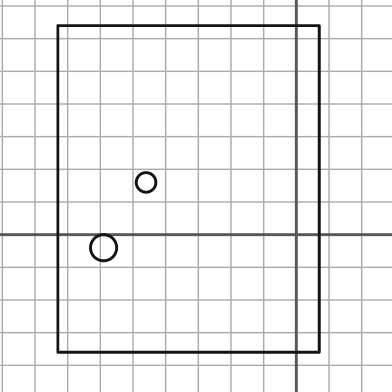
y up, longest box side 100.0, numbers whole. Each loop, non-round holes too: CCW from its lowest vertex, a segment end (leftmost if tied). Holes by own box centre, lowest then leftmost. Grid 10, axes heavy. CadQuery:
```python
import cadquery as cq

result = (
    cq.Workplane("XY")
    .moveTo(-73.0, -36.0)
    .lineTo(7.0, -36.0)
    .lineTo(7.0, 64.0)
    .lineTo(-73.0, 64.0)
    .close()
    .moveTo(-59.0, -4.0)
    .circle(4.0)
    .moveTo(-46.0, 16.0)
    .circle(3.0)
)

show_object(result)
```